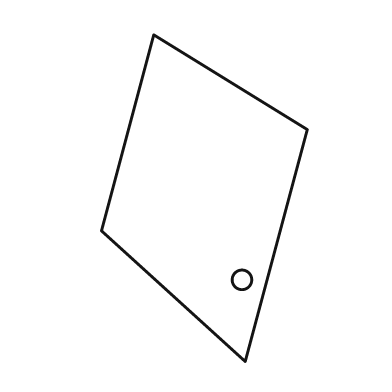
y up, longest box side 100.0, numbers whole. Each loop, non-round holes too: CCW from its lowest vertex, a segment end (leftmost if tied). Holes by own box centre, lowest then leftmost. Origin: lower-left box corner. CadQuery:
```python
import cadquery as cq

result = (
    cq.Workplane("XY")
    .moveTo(44.0, 0.0)
    .lineTo(63.0, 71.0)
    .lineTo(16.0, 100.0)
    .lineTo(0.0, 40.0)
    .close()
    .moveTo(43.0, 25.0)
    .circle(3.0)
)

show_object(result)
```